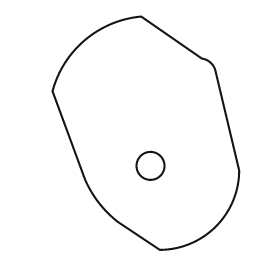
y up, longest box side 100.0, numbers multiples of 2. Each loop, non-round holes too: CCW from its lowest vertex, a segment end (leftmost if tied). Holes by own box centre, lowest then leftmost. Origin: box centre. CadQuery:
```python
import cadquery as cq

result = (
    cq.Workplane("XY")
    .moveTo(6.0, -50.0)
    .threePointArc((30.0, -40.0), (40.0, -16.0))
    .lineTo(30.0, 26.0)
    .threePointArc((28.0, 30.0), (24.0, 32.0))
    .lineTo(-2.0, 50.0)
    .threePointArc((-26.0, 40.0), (-40.0, 18.0))
    .lineTo(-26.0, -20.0)
    .threePointArc((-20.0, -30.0), (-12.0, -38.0))
    .close()
    .moveTo(2.0, -14.0)
    .circle(6.0)
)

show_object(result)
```